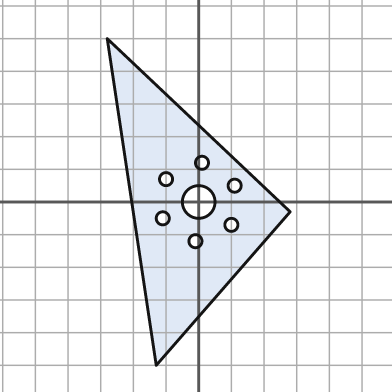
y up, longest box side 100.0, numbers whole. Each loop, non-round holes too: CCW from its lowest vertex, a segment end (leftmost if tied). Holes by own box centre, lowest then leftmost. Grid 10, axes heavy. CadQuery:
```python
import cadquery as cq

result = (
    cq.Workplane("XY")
    .moveTo(-13.0, -50.0)
    .lineTo(28.0, -3.0)
    .lineTo(-28.0, 50.0)
    .close()
    .moveTo(-1.0, -12.0)
    .circle(2.0)
    .moveTo(10.0, -7.0)
    .circle(2.0)
    .moveTo(-11.0, -5.0)
    .circle(2.0)
    .moveTo(0.0, 0.0)
    .circle(5.0)
    .moveTo(11.0, 5.0)
    .circle(2.0)
    .moveTo(-10.0, 7.0)
    .circle(2.0)
    .moveTo(1.0, 12.0)
    .circle(2.0)
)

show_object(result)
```